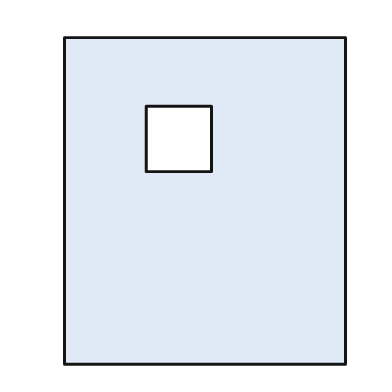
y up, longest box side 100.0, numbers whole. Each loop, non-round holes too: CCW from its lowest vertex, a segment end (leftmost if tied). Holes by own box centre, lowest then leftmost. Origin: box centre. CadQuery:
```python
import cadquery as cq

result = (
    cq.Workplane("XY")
    .moveTo(-43.0, -50.0)
    .lineTo(43.0, -50.0)
    .lineTo(43.0, 50.0)
    .lineTo(-43.0, 50.0)
    .close()
    .moveTo(-18.0, 9.0)
    .lineTo(2.0, 9.0)
    .lineTo(2.0, 29.0)
    .lineTo(-18.0, 29.0)
    .close()
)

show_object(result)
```